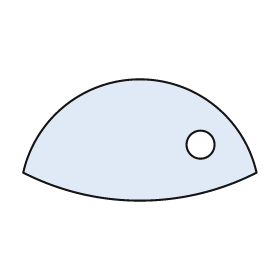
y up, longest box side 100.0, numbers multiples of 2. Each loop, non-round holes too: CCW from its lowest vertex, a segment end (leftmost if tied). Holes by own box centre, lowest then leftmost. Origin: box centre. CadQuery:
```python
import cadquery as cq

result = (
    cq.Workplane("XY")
    .moveTo(-50.0, -14.0)
    .threePointArc((0.0, -26.0), (50.0, -14.0))
    .threePointArc((0.0, 26.0), (-50.0, -14.0))
    .close()
    .moveTo(26.0, -2.0)
    .circle(6.0)
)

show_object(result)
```